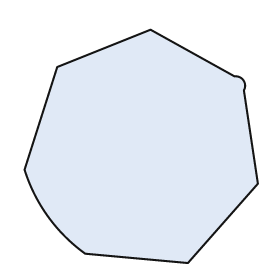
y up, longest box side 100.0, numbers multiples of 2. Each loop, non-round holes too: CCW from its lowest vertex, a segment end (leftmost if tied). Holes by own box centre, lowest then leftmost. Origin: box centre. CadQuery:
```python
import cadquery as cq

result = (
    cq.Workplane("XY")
    .moveTo(20.0, -50.0)
    .lineTo(50.0, -16.0)
    .lineTo(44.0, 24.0)
    .threePointArc((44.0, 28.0), (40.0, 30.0))
    .lineTo(4.0, 50.0)
    .lineTo(-36.0, 34.0)
    .lineTo(-50.0, -10.0)
    .threePointArc((-40.0, -30.0), (-24.0, -46.0))
    .close()
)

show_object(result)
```